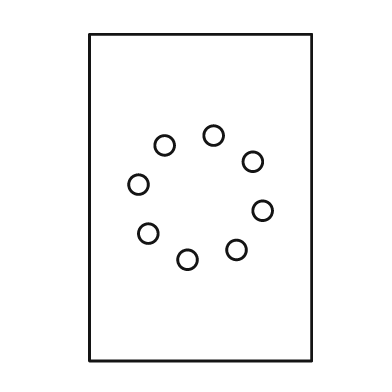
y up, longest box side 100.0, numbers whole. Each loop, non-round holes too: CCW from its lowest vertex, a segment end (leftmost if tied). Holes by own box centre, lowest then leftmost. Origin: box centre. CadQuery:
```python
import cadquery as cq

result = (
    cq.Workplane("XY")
    .moveTo(-34.0, -50.0)
    .lineTo(34.0, -50.0)
    .lineTo(34.0, 50.0)
    .lineTo(-34.0, 50.0)
    .close()
    .moveTo(-4.0, -19.0)
    .circle(3.0)
    .moveTo(11.0, -16.0)
    .circle(3.0)
    .moveTo(-16.0, -11.0)
    .circle(3.0)
    .moveTo(19.0, -4.0)
    .circle(3.0)
    .moveTo(-19.0, 4.0)
    .circle(3.0)
    .moveTo(16.0, 11.0)
    .circle(3.0)
    .moveTo(-11.0, 16.0)
    .circle(3.0)
    .moveTo(4.0, 19.0)
    .circle(3.0)
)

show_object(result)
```